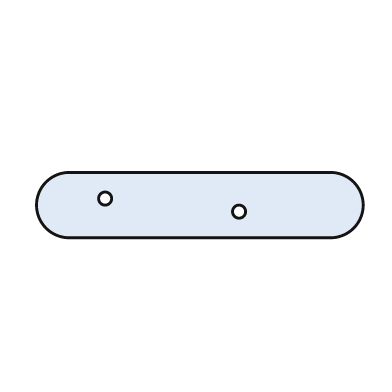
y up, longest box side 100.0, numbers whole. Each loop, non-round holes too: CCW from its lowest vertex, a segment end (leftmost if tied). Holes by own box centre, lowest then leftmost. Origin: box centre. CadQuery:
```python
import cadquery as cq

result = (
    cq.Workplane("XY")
    .moveTo(-40.0, -10.0)
    .lineTo(40.0, -10.0)
    .threePointArc((50.0, 0.0), (40.0, 10.0))
    .lineTo(-40.0, 10.0)
    .threePointArc((-50.0, 0.0), (-40.0, -10.0))
    .close()
    .moveTo(12.0, -2.0)
    .circle(2.0)
    .moveTo(-29.0, 2.0)
    .circle(2.0)
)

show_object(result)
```